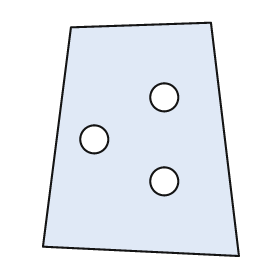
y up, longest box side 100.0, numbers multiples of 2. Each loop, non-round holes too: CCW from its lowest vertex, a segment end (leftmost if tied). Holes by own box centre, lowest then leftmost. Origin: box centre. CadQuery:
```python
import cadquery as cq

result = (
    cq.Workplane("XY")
    .moveTo(42.0, -50.0)
    .lineTo(30.0, 50.0)
    .lineTo(-30.0, 48.0)
    .lineTo(-42.0, -46.0)
    .close()
    .moveTo(10.0, -18.0)
    .circle(6.0)
    .moveTo(-20.0, 0.0)
    .circle(6.0)
    .moveTo(10.0, 18.0)
    .circle(6.0)
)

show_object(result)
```